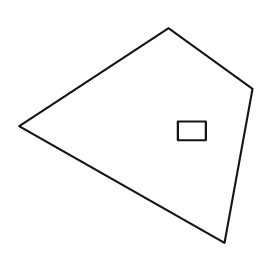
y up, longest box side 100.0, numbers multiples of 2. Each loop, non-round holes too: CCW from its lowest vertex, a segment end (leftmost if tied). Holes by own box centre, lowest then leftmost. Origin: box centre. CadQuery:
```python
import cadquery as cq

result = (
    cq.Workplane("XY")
    .moveTo(38.0, -46.0)
    .lineTo(50.0, 20.0)
    .lineTo(14.0, 46.0)
    .lineTo(-50.0, 4.0)
    .close()
    .moveTo(18.0, -2.0)
    .lineTo(30.0, -2.0)
    .lineTo(30.0, 6.0)
    .lineTo(18.0, 6.0)
    .close()
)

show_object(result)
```